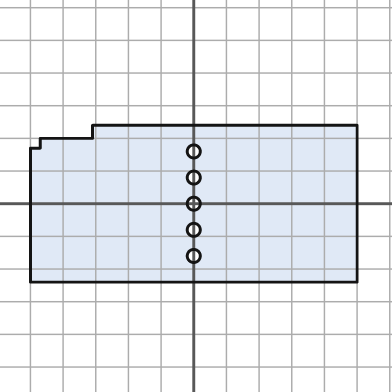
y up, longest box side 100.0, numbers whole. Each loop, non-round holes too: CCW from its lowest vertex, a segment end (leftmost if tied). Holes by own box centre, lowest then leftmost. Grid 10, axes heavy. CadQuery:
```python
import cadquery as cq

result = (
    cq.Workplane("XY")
    .moveTo(-50.0, -24.0)
    .lineTo(50.0, -24.0)
    .lineTo(50.0, 24.0)
    .lineTo(-31.0, 24.0)
    .lineTo(-31.0, 20.0)
    .lineTo(-47.0, 20.0)
    .lineTo(-47.0, 17.0)
    .lineTo(-50.0, 17.0)
    .close()
    .moveTo(0.0, -16.0)
    .circle(2.0)
    .moveTo(0.0, -8.0)
    .circle(2.0)
    .moveTo(0.0, 0.0)
    .circle(2.0)
    .moveTo(0.0, 8.0)
    .circle(2.0)
    .moveTo(0.0, 16.0)
    .circle(2.0)
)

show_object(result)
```